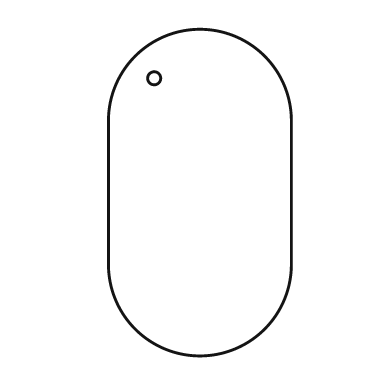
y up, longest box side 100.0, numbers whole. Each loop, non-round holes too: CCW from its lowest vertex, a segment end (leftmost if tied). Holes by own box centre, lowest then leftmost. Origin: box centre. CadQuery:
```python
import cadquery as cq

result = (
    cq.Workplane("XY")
    .moveTo(-28.0, -22.0)
    .threePointArc((0.0, -50.0), (28.0, -22.0))
    .lineTo(28.0, 22.0)
    .threePointArc((0.0, 50.0), (-28.0, 22.0))
    .close()
    .moveTo(-14.0, 35.0)
    .circle(2.0)
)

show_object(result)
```